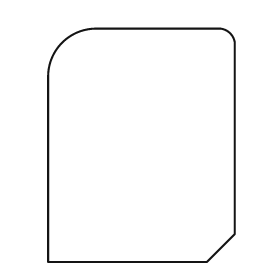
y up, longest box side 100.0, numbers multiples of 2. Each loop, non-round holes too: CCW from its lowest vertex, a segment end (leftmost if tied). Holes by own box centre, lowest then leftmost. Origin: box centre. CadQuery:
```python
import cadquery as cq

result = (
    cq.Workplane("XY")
    .moveTo(-40.0, -50.0)
    .lineTo(28.0, -50.0)
    .lineTo(40.0, -38.0)
    .lineTo(40.0, 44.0)
    .threePointArc((38.0, 48.0), (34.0, 50.0))
    .lineTo(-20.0, 50.0)
    .threePointArc((-34.0, 44.0), (-40.0, 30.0))
    .close()
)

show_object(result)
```